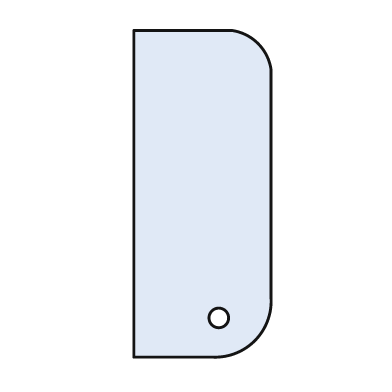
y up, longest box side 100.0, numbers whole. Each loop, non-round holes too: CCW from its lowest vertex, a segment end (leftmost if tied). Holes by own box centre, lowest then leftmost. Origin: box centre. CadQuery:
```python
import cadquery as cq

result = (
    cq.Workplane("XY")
    .moveTo(-21.0, -50.0)
    .lineTo(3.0, -50.0)
    .threePointArc((16.0, -45.0), (21.0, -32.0))
    .lineTo(21.0, 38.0)
    .threePointArc((17.0, 46.0), (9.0, 50.0))
    .lineTo(-21.0, 50.0)
    .close()
    .moveTo(5.0, -38.0)
    .circle(3.0)
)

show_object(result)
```